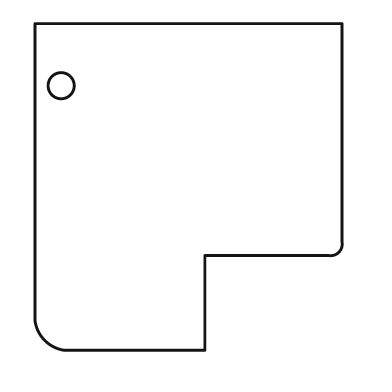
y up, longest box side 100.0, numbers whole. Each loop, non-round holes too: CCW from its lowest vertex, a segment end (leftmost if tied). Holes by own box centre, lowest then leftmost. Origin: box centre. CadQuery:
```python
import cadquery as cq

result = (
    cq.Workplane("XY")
    .moveTo(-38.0, -50.0)
    .lineTo(5.0, -50.0)
    .lineTo(5.0, -21.0)
    .lineTo(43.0, -21.0)
    .threePointArc((46.0, -20.0), (47.0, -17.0))
    .lineTo(47.0, 50.0)
    .lineTo(-47.0, 50.0)
    .lineTo(-47.0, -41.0)
    .threePointArc((-44.0, -47.0), (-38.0, -50.0))
    .close()
    .moveTo(-39.0, 31.0)
    .circle(4.0)
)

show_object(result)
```